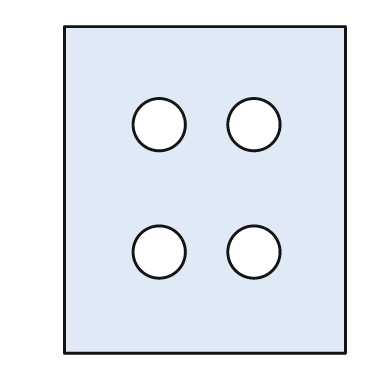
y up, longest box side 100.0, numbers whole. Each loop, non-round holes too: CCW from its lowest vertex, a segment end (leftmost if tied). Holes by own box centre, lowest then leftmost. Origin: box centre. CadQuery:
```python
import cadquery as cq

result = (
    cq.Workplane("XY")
    .moveTo(-43.0, -50.0)
    .lineTo(43.0, -50.0)
    .lineTo(43.0, 50.0)
    .lineTo(-43.0, 50.0)
    .close()
    .moveTo(-14.0, -19.0)
    .circle(8.0)
    .moveTo(15.0, -19.0)
    .circle(8.0)
    .moveTo(-14.0, 20.0)
    .circle(8.0)
    .moveTo(15.0, 20.0)
    .circle(8.0)
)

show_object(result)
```